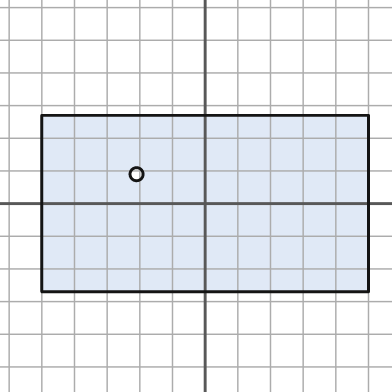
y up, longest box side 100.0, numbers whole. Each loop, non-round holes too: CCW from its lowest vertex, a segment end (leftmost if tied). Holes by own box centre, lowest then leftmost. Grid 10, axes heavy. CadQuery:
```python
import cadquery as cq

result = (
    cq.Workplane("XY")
    .moveTo(-50.0, -27.0)
    .lineTo(50.0, -27.0)
    .lineTo(50.0, 27.0)
    .lineTo(-50.0, 27.0)
    .close()
    .moveTo(-21.0, 9.0)
    .circle(2.0)
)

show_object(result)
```